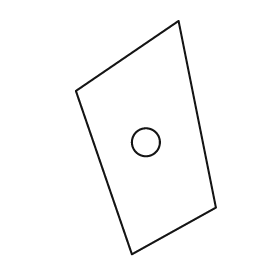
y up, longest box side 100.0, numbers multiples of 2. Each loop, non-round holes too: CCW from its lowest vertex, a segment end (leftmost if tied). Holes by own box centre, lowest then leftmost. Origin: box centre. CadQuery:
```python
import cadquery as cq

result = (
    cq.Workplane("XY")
    .moveTo(-6.0, -50.0)
    .lineTo(30.0, -30.0)
    .lineTo(14.0, 50.0)
    .lineTo(-30.0, 20.0)
    .close()
    .moveTo(0.0, -2.0)
    .circle(6.0)
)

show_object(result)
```